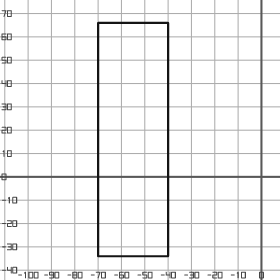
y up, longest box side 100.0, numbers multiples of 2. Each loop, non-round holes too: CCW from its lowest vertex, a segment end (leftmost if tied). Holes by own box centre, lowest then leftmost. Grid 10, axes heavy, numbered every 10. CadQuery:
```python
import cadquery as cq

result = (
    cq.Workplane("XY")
    .moveTo(-70.0, -34.0)
    .lineTo(-40.0, -34.0)
    .lineTo(-40.0, 66.0)
    .lineTo(-70.0, 66.0)
    .close()
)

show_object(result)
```